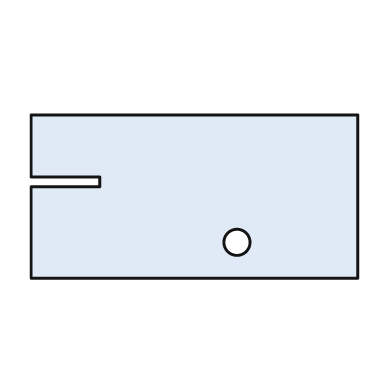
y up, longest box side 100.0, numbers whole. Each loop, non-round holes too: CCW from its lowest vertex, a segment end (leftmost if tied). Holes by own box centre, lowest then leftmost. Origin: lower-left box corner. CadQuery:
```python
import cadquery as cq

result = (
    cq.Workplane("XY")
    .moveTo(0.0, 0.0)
    .lineTo(100.0, 0.0)
    .lineTo(100.0, 50.0)
    .lineTo(0.0, 50.0)
    .lineTo(0.0, 31.0)
    .lineTo(21.0, 31.0)
    .lineTo(21.0, 28.0)
    .lineTo(0.0, 28.0)
    .close()
    .moveTo(63.0, 11.0)
    .circle(4.0)
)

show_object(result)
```